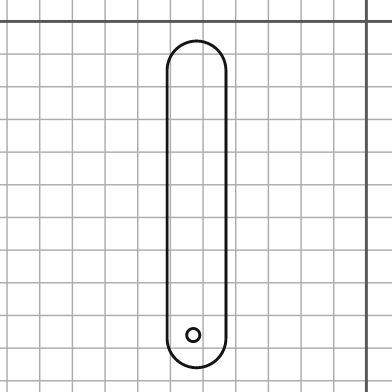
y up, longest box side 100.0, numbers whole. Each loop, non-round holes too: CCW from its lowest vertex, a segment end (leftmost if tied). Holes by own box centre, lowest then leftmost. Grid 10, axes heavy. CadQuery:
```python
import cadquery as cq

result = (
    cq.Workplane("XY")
    .moveTo(-61.0, -97.0)
    .threePointArc((-52.0, -106.0), (-43.0, -97.0))
    .lineTo(-43.0, -15.0)
    .threePointArc((-52.0, -6.0), (-61.0, -15.0))
    .close()
    .moveTo(-53.0, -96.0)
    .circle(2.0)
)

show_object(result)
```